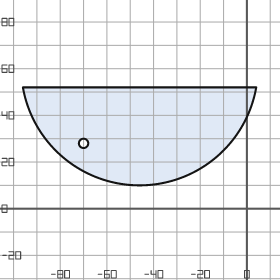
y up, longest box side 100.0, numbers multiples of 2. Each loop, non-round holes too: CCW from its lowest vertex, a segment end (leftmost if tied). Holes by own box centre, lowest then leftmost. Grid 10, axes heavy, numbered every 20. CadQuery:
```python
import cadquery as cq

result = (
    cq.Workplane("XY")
    .moveTo(-96.0, 52.0)
    .threePointArc((-46.0, 10.0), (4.0, 52.0))
    .close()
    .moveTo(-70.0, 28.0)
    .circle(2.0)
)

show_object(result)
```